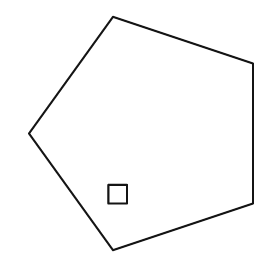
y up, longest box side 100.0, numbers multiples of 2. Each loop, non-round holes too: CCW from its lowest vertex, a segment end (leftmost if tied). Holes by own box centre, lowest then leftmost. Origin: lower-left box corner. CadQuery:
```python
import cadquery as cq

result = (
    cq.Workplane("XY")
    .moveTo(36.0, 0.0)
    .lineTo(96.0, 20.0)
    .lineTo(96.0, 80.0)
    .lineTo(36.0, 100.0)
    .lineTo(0.0, 50.0)
    .close()
    .moveTo(34.0, 20.0)
    .lineTo(42.0, 20.0)
    .lineTo(42.0, 28.0)
    .lineTo(34.0, 28.0)
    .close()
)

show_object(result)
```